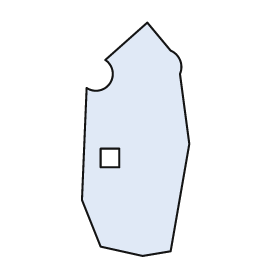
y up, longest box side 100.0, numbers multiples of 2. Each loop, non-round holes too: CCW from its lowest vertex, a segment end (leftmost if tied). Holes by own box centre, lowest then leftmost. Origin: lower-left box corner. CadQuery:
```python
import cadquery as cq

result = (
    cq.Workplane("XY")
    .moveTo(26.0, 0.0)
    .lineTo(38.0, 2.0)
    .lineTo(46.0, 48.0)
    .lineTo(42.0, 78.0)
    .threePointArc((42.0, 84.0), (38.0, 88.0))
    .lineTo(28.0, 100.0)
    .lineTo(10.0, 84.0)
    .threePointArc((12.0, 74.0), (2.0, 72.0))
    .lineTo(0.0, 24.0)
    .lineTo(8.0, 4.0)
    .close()
    .moveTo(8.0, 38.0)
    .lineTo(16.0, 38.0)
    .lineTo(16.0, 46.0)
    .lineTo(8.0, 46.0)
    .close()
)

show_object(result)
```